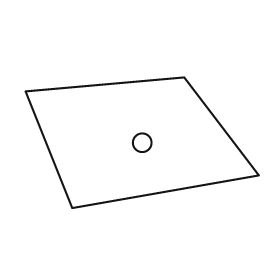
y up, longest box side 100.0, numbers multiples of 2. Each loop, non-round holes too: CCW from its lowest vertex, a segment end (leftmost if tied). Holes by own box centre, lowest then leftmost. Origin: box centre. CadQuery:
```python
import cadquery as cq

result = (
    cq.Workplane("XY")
    .moveTo(-30.0, -28.0)
    .lineTo(50.0, -14.0)
    .lineTo(18.0, 28.0)
    .lineTo(-50.0, 22.0)
    .close()
    .moveTo(0.0, 0.0)
    .circle(4.0)
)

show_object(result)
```